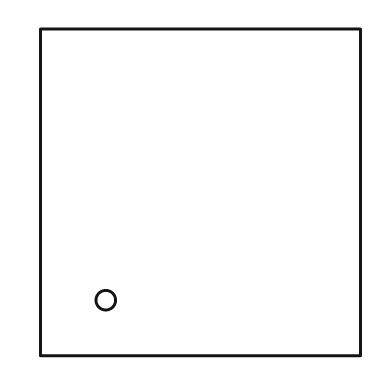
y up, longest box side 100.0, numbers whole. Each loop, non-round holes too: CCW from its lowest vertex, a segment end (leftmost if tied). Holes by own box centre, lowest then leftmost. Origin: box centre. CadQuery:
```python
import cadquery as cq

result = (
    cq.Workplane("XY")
    .moveTo(-49.0, -50.0)
    .lineTo(49.0, -50.0)
    .lineTo(49.0, 50.0)
    .lineTo(-49.0, 50.0)
    .close()
    .moveTo(-29.0, -33.0)
    .circle(3.0)
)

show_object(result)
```